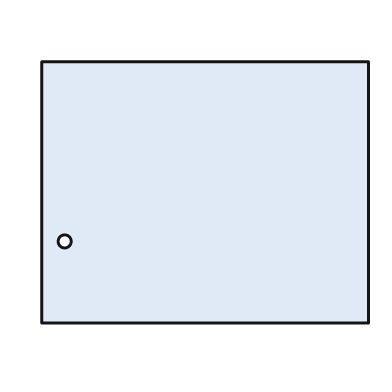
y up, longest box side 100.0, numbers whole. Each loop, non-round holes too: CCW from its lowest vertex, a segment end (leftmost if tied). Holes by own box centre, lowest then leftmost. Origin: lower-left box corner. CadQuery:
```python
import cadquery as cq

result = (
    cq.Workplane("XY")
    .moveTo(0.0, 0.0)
    .lineTo(100.0, 0.0)
    .lineTo(100.0, 80.0)
    .lineTo(0.0, 80.0)
    .close()
    .moveTo(7.0, 25.0)
    .circle(2.0)
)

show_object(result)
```